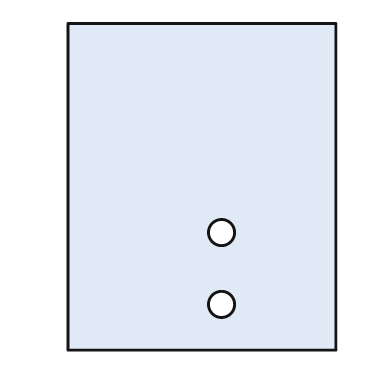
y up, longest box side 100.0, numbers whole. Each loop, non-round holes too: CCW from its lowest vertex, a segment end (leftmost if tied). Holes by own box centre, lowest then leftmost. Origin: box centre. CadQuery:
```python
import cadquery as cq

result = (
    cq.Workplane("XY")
    .moveTo(-41.0, -50.0)
    .lineTo(41.0, -50.0)
    .lineTo(41.0, 50.0)
    .lineTo(-41.0, 50.0)
    .close()
    .moveTo(6.0, -36.0)
    .circle(4.0)
    .moveTo(6.0, -14.0)
    .circle(4.0)
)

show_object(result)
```